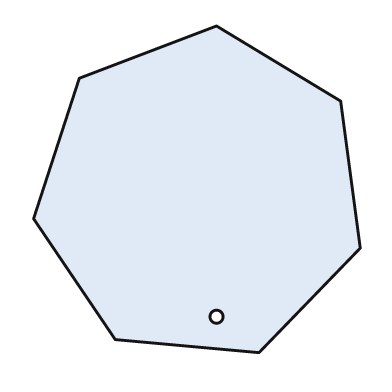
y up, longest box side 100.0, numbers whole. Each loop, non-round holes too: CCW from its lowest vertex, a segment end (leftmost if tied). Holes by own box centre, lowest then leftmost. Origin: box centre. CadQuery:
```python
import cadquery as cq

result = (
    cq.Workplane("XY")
    .moveTo(19.0, -50.0)
    .lineTo(50.0, -18.0)
    .lineTo(44.0, 27.0)
    .lineTo(6.0, 50.0)
    .lineTo(-36.0, 34.0)
    .lineTo(-50.0, -9.0)
    .lineTo(-25.0, -46.0)
    .close()
    .moveTo(6.0, -39.0)
    .circle(2.0)
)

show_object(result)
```